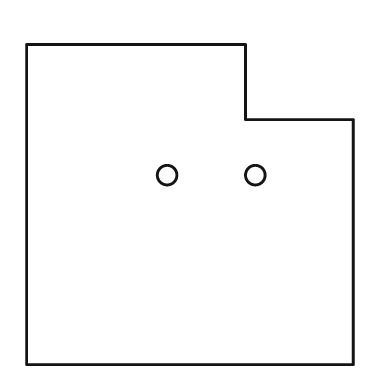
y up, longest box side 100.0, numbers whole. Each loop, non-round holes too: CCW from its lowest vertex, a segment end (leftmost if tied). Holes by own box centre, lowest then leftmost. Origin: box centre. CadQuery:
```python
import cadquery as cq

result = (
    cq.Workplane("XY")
    .moveTo(-50.0, -49.0)
    .lineTo(50.0, -49.0)
    .lineTo(50.0, 26.0)
    .lineTo(17.0, 26.0)
    .lineTo(17.0, 49.0)
    .lineTo(-50.0, 49.0)
    .close()
    .moveTo(-7.0, 9.0)
    .circle(3.0)
    .moveTo(20.0, 9.0)
    .circle(3.0)
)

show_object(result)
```